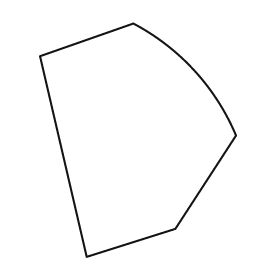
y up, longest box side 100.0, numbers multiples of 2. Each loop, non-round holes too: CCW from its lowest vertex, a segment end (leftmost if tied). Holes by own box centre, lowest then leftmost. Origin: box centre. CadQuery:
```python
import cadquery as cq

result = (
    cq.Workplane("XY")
    .moveTo(-22.0, -50.0)
    .lineTo(16.0, -38.0)
    .lineTo(42.0, 2.0)
    .threePointArc((24.0, 30.0), (-2.0, 50.0))
    .lineTo(-42.0, 36.0)
    .close()
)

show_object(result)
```